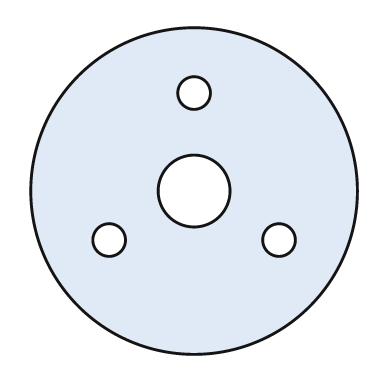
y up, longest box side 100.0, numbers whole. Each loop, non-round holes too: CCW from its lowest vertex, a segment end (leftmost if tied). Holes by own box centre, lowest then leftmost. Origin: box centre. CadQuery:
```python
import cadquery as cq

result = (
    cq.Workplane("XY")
    .moveTo(0.0, 0.0)
    .circle(50.0)
    .moveTo(-26.0, -15.0)
    .circle(5.0)
    .moveTo(26.0, -15.0)
    .circle(5.0)
    .moveTo(0.0, 0.0)
    .circle(11.0)
    .moveTo(0.0, 30.0)
    .circle(5.0)
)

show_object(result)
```